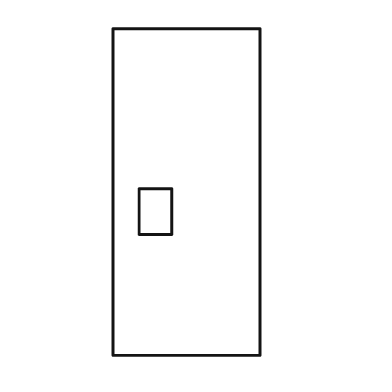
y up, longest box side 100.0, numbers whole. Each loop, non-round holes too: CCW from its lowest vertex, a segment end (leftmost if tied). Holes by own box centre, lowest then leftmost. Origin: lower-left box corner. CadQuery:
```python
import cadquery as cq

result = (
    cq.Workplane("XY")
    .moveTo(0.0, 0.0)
    .lineTo(45.0, 0.0)
    .lineTo(45.0, 100.0)
    .lineTo(0.0, 100.0)
    .close()
    .moveTo(8.0, 37.0)
    .lineTo(18.0, 37.0)
    .lineTo(18.0, 51.0)
    .lineTo(8.0, 51.0)
    .close()
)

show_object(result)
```